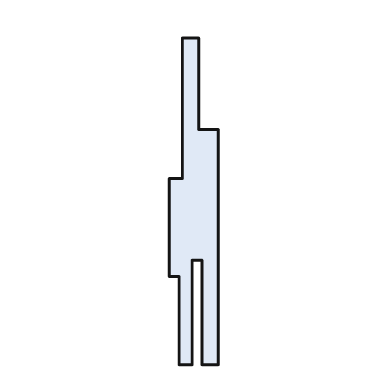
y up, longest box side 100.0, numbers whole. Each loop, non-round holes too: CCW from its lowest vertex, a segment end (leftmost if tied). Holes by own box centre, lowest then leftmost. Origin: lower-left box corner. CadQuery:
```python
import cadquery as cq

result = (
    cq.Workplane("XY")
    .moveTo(3.0, 0.0)
    .lineTo(7.0, 0.0)
    .lineTo(7.0, 32.0)
    .lineTo(10.0, 32.0)
    .lineTo(10.0, 0.0)
    .lineTo(15.0, 0.0)
    .lineTo(15.0, 72.0)
    .lineTo(9.0, 72.0)
    .lineTo(9.0, 100.0)
    .lineTo(4.0, 100.0)
    .lineTo(4.0, 57.0)
    .lineTo(0.0, 57.0)
    .lineTo(0.0, 27.0)
    .lineTo(3.0, 27.0)
    .close()
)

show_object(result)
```